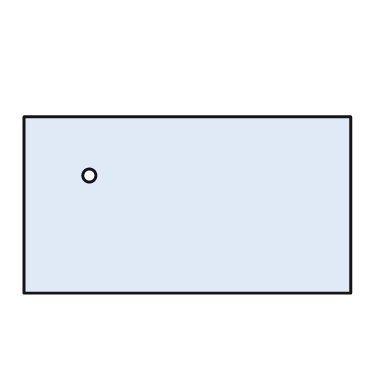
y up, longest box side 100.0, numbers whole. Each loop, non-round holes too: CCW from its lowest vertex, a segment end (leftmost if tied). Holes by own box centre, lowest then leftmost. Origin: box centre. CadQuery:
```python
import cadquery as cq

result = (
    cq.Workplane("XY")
    .moveTo(-50.0, -27.0)
    .lineTo(50.0, -27.0)
    .lineTo(50.0, 27.0)
    .lineTo(-50.0, 27.0)
    .close()
    .moveTo(-30.0, 9.0)
    .circle(2.0)
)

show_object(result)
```